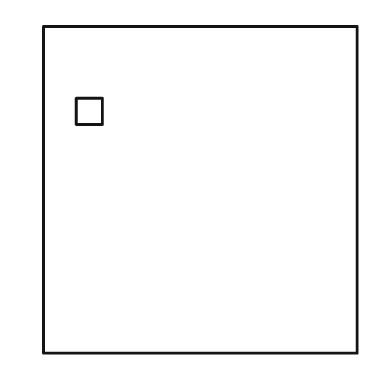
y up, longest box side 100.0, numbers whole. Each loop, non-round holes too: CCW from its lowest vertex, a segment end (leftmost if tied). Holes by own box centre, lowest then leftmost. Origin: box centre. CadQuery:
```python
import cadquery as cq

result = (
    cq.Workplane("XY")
    .moveTo(-48.0, -50.0)
    .lineTo(48.0, -50.0)
    .lineTo(48.0, 50.0)
    .lineTo(-48.0, 50.0)
    .close()
    .moveTo(-38.0, 20.0)
    .lineTo(-30.0, 20.0)
    .lineTo(-30.0, 28.0)
    .lineTo(-38.0, 28.0)
    .close()
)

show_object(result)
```